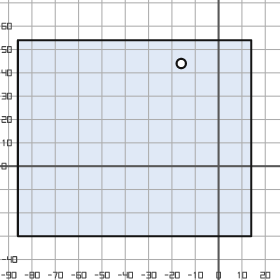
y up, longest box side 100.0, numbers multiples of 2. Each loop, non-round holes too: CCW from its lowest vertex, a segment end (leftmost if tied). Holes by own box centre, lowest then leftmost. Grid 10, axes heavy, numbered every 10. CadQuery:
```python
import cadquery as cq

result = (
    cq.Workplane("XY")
    .moveTo(-86.0, -30.0)
    .lineTo(14.0, -30.0)
    .lineTo(14.0, 54.0)
    .lineTo(-86.0, 54.0)
    .close()
    .moveTo(-16.0, 44.0)
    .circle(2.0)
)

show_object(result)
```